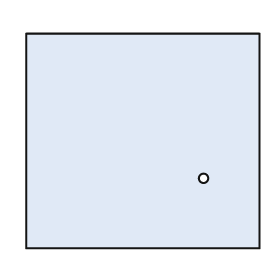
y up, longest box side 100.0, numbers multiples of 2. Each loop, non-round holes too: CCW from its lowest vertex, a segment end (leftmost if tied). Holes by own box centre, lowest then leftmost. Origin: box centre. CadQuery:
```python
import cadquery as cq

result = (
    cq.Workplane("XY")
    .moveTo(-50.0, -46.0)
    .lineTo(50.0, -46.0)
    .lineTo(50.0, 46.0)
    .lineTo(-50.0, 46.0)
    .close()
    .moveTo(26.0, -16.0)
    .circle(2.0)
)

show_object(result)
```